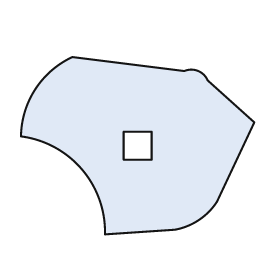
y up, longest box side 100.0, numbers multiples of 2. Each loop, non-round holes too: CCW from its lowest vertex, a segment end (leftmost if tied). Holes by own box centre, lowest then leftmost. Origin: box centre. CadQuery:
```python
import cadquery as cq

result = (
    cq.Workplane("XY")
    .moveTo(-14.0, -38.0)
    .lineTo(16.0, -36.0)
    .threePointArc((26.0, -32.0), (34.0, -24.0))
    .lineTo(50.0, 10.0)
    .lineTo(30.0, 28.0)
    .threePointArc((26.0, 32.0), (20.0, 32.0))
    .lineTo(-28.0, 38.0)
    .threePointArc((-44.0, 24.0), (-50.0, 4.0))
    .threePointArc((-24.0, -10.0), (-14.0, -38.0))
    .close()
    .moveTo(-6.0, -6.0)
    .lineTo(6.0, -6.0)
    .lineTo(6.0, 6.0)
    .lineTo(-6.0, 6.0)
    .close()
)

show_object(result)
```